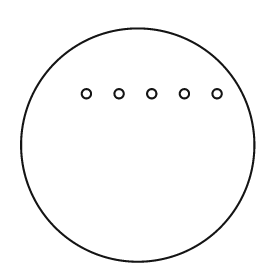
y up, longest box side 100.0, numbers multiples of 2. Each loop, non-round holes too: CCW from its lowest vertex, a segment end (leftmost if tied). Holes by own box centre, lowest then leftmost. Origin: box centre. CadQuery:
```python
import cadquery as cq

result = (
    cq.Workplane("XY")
    .moveTo(0.0, 0.0)
    .circle(50.0)
    .moveTo(-22.0, 22.0)
    .circle(2.0)
    .moveTo(-8.0, 22.0)
    .circle(2.0)
    .moveTo(6.0, 22.0)
    .circle(2.0)
    .moveTo(20.0, 22.0)
    .circle(2.0)
    .moveTo(34.0, 22.0)
    .circle(2.0)
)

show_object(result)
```